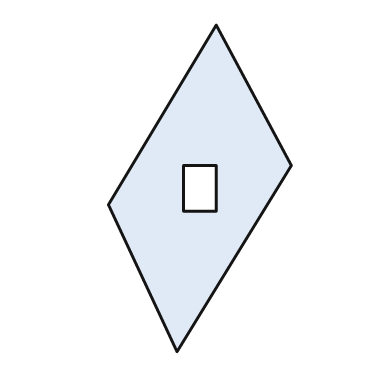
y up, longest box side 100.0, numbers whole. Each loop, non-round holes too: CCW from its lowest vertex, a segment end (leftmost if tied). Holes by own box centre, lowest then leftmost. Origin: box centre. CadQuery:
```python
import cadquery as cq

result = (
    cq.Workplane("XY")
    .moveTo(-7.0, -50.0)
    .lineTo(28.0, 7.0)
    .lineTo(5.0, 50.0)
    .lineTo(-28.0, -5.0)
    .close()
    .moveTo(-5.0, -7.0)
    .lineTo(5.0, -7.0)
    .lineTo(5.0, 7.0)
    .lineTo(-5.0, 7.0)
    .close()
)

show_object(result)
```